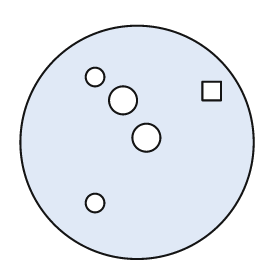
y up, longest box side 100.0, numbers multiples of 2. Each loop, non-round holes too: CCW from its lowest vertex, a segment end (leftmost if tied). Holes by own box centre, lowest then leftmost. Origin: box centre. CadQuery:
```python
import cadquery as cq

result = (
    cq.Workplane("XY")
    .moveTo(0.0, 0.0)
    .circle(50.0)
    .moveTo(-18.0, -26.0)
    .circle(4.0)
    .moveTo(4.0, 2.0)
    .circle(6.0)
    .moveTo(-6.0, 18.0)
    .circle(6.0)
    .moveTo(28.0, 18.0)
    .lineTo(36.0, 18.0)
    .lineTo(36.0, 26.0)
    .lineTo(28.0, 26.0)
    .close()
    .moveTo(-18.0, 28.0)
    .circle(4.0)
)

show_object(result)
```